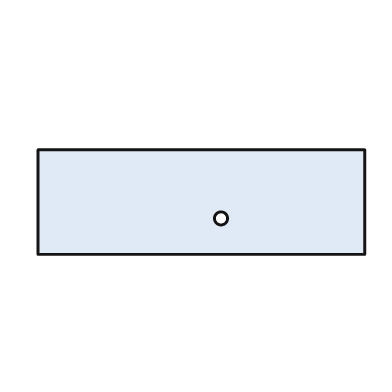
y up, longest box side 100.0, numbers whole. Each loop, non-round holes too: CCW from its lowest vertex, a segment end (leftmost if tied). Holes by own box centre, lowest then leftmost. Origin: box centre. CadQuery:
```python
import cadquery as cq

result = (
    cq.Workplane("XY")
    .moveTo(-50.0, -16.0)
    .lineTo(50.0, -16.0)
    .lineTo(50.0, 16.0)
    .lineTo(-50.0, 16.0)
    .close()
    .moveTo(6.0, -5.0)
    .circle(2.0)
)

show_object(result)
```